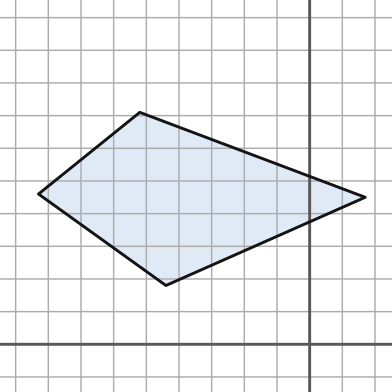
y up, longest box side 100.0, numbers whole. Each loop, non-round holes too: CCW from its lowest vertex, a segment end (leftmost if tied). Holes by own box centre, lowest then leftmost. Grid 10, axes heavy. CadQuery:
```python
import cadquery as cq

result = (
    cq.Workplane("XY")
    .moveTo(-44.0, 18.0)
    .lineTo(17.0, 45.0)
    .lineTo(-52.0, 71.0)
    .lineTo(-83.0, 46.0)
    .close()
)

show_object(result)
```